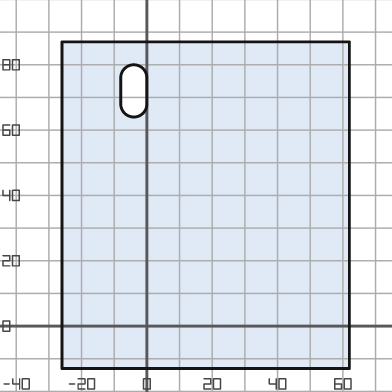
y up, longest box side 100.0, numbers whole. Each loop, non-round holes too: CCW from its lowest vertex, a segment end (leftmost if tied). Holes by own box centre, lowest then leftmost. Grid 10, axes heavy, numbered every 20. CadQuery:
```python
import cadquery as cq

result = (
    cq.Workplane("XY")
    .moveTo(-26.0, -13.0)
    .lineTo(62.0, -13.0)
    .lineTo(62.0, 87.0)
    .lineTo(-26.0, 87.0)
    .close()
    .moveTo(-8.0, 68.0)
    .threePointArc((-4.0, 64.0), (0.0, 68.0))
    .lineTo(0.0, 76.0)
    .threePointArc((-4.0, 80.0), (-8.0, 76.0))
    .close()
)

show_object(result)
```